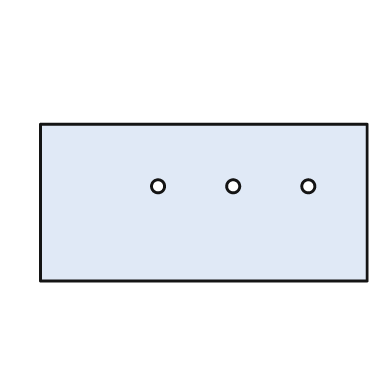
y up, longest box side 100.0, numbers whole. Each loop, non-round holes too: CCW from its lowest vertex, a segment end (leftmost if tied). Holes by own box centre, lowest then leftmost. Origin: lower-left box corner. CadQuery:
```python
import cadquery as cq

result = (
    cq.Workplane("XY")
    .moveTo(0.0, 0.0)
    .lineTo(100.0, 0.0)
    .lineTo(100.0, 48.0)
    .lineTo(0.0, 48.0)
    .close()
    .moveTo(36.0, 29.0)
    .circle(2.0)
    .moveTo(59.0, 29.0)
    .circle(2.0)
    .moveTo(82.0, 29.0)
    .circle(2.0)
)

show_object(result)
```